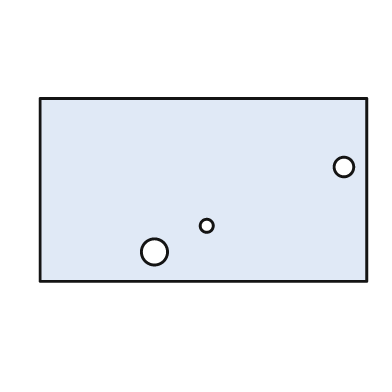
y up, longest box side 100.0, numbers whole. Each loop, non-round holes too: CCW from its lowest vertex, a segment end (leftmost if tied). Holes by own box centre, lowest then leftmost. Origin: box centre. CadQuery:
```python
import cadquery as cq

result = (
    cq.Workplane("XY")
    .moveTo(-50.0, -28.0)
    .lineTo(50.0, -28.0)
    .lineTo(50.0, 28.0)
    .lineTo(-50.0, 28.0)
    .close()
    .moveTo(-15.0, -19.0)
    .circle(4.0)
    .moveTo(1.0, -11.0)
    .circle(2.0)
    .moveTo(43.0, 7.0)
    .circle(3.0)
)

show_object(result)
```